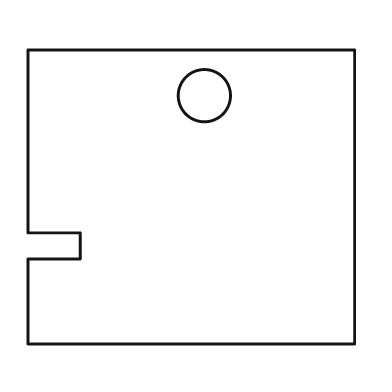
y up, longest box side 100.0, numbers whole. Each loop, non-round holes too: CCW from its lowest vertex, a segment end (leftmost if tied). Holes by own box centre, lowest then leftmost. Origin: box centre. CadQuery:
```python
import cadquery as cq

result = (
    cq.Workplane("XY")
    .moveTo(-50.0, -45.0)
    .lineTo(50.0, -45.0)
    .lineTo(50.0, 45.0)
    .lineTo(-50.0, 45.0)
    .lineTo(-50.0, -11.0)
    .lineTo(-34.0, -11.0)
    .lineTo(-34.0, -19.0)
    .lineTo(-50.0, -19.0)
    .close()
    .moveTo(4.0, 31.0)
    .circle(8.0)
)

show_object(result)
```